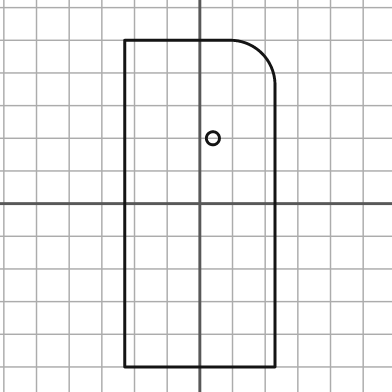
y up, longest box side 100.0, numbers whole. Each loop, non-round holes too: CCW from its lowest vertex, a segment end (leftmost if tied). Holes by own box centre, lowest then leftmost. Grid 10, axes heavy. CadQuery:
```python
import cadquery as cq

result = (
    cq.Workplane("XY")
    .moveTo(-23.0, -50.0)
    .lineTo(23.0, -50.0)
    .lineTo(23.0, 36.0)
    .threePointArc((19.0, 46.0), (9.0, 50.0))
    .lineTo(-23.0, 50.0)
    .close()
    .moveTo(4.0, 20.0)
    .circle(2.0)
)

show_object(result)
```